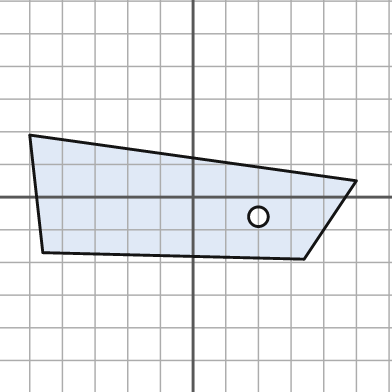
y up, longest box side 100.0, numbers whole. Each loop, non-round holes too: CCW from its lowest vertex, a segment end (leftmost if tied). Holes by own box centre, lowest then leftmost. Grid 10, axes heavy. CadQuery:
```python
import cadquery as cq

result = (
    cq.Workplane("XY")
    .moveTo(34.0, -19.0)
    .lineTo(50.0, 5.0)
    .lineTo(-50.0, 19.0)
    .lineTo(-46.0, -17.0)
    .close()
    .moveTo(20.0, -6.0)
    .circle(3.0)
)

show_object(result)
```